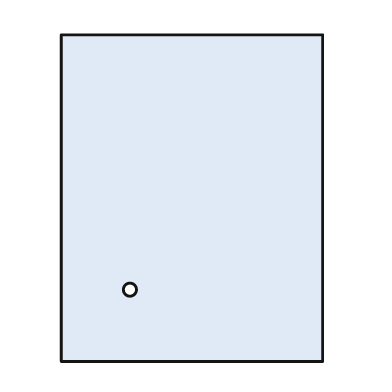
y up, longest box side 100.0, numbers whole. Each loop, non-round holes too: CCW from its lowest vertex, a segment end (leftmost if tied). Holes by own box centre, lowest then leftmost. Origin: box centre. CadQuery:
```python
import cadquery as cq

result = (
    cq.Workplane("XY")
    .moveTo(-40.0, -50.0)
    .lineTo(40.0, -50.0)
    .lineTo(40.0, 50.0)
    .lineTo(-40.0, 50.0)
    .close()
    .moveTo(-19.0, -28.0)
    .circle(2.0)
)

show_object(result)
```